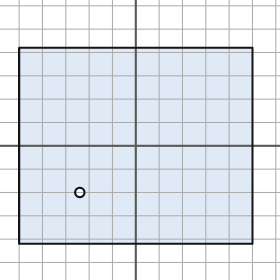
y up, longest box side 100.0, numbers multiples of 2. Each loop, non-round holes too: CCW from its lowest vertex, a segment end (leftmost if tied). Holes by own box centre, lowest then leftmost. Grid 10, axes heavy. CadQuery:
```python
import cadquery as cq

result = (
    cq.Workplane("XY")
    .moveTo(-50.0, -42.0)
    .lineTo(50.0, -42.0)
    .lineTo(50.0, 42.0)
    .lineTo(-50.0, 42.0)
    .close()
    .moveTo(-24.0, -20.0)
    .circle(2.0)
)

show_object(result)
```